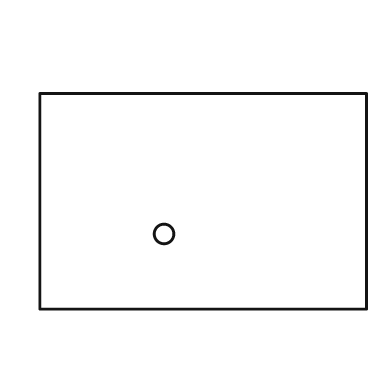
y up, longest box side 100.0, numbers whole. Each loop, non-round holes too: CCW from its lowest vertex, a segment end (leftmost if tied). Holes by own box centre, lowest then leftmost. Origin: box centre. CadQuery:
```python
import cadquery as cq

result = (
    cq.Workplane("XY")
    .moveTo(-50.0, -33.0)
    .lineTo(50.0, -33.0)
    .lineTo(50.0, 33.0)
    .lineTo(-50.0, 33.0)
    .close()
    .moveTo(-12.0, -10.0)
    .circle(3.0)
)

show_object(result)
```